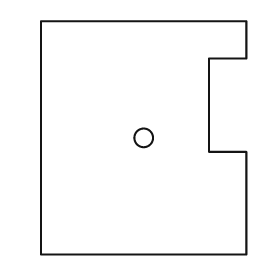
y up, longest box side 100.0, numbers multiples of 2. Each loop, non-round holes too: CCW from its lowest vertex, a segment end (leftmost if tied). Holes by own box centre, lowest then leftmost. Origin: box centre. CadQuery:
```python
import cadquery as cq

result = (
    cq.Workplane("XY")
    .moveTo(-44.0, -50.0)
    .lineTo(44.0, -50.0)
    .lineTo(44.0, -6.0)
    .lineTo(28.0, -6.0)
    .lineTo(28.0, 34.0)
    .lineTo(44.0, 34.0)
    .lineTo(44.0, 50.0)
    .lineTo(-44.0, 50.0)
    .close()
    .moveTo(0.0, 0.0)
    .circle(4.0)
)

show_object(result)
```